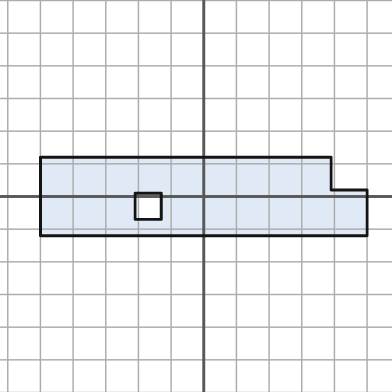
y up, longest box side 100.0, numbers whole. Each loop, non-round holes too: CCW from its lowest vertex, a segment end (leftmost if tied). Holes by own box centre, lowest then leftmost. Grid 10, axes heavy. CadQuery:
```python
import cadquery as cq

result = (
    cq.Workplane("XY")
    .moveTo(-50.0, -12.0)
    .lineTo(50.0, -12.0)
    .lineTo(50.0, 2.0)
    .lineTo(39.0, 2.0)
    .lineTo(39.0, 12.0)
    .lineTo(-50.0, 12.0)
    .close()
    .moveTo(-21.0, -7.0)
    .lineTo(-13.0, -7.0)
    .lineTo(-13.0, 1.0)
    .lineTo(-21.0, 1.0)
    .close()
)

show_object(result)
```